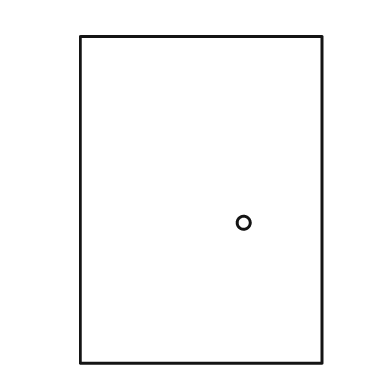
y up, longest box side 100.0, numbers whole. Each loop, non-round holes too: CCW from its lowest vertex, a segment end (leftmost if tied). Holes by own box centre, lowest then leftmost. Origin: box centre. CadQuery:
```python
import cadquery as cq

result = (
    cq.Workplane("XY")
    .moveTo(-37.0, -50.0)
    .lineTo(37.0, -50.0)
    .lineTo(37.0, 50.0)
    .lineTo(-37.0, 50.0)
    .close()
    .moveTo(13.0, -7.0)
    .circle(2.0)
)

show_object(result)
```